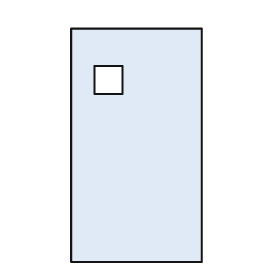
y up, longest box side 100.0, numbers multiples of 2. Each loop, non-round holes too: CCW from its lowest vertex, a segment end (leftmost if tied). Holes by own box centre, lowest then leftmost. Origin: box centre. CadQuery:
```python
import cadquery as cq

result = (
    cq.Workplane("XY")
    .moveTo(-28.0, -50.0)
    .lineTo(28.0, -50.0)
    .lineTo(28.0, 50.0)
    .lineTo(-28.0, 50.0)
    .close()
    .moveTo(-18.0, 22.0)
    .lineTo(-6.0, 22.0)
    .lineTo(-6.0, 34.0)
    .lineTo(-18.0, 34.0)
    .close()
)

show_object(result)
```